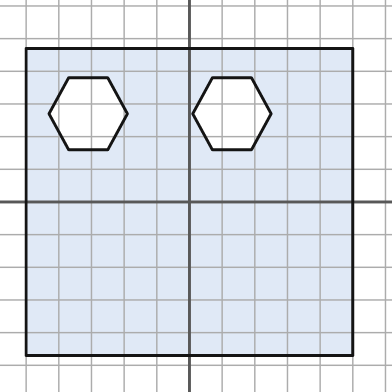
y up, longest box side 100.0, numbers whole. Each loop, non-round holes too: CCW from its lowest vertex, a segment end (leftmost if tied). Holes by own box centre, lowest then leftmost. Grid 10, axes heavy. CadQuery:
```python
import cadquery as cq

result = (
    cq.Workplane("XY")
    .moveTo(-50.0, -47.0)
    .lineTo(50.0, -47.0)
    .lineTo(50.0, 47.0)
    .lineTo(-50.0, 47.0)
    .close()
    .moveTo(-37.0, 16.0)
    .lineTo(-25.0, 16.0)
    .lineTo(-19.0, 27.0)
    .lineTo(-25.0, 38.0)
    .lineTo(-37.0, 38.0)
    .lineTo(-43.0, 27.0)
    .close()
    .moveTo(7.0, 16.0)
    .lineTo(19.0, 16.0)
    .lineTo(25.0, 27.0)
    .lineTo(19.0, 38.0)
    .lineTo(7.0, 38.0)
    .lineTo(1.0, 27.0)
    .close()
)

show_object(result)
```